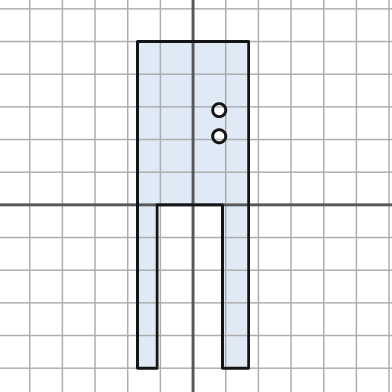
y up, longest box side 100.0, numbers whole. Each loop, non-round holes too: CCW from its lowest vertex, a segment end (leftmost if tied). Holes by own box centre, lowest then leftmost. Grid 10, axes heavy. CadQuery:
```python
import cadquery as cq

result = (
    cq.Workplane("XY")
    .moveTo(-17.0, -50.0)
    .lineTo(-11.0, -50.0)
    .lineTo(-11.0, 0.0)
    .lineTo(9.0, 0.0)
    .lineTo(9.0, -50.0)
    .lineTo(17.0, -50.0)
    .lineTo(17.0, 50.0)
    .lineTo(-17.0, 50.0)
    .close()
    .moveTo(8.0, 21.0)
    .circle(2.0)
    .moveTo(8.0, 29.0)
    .circle(2.0)
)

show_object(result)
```